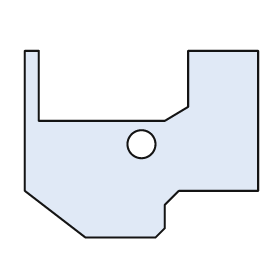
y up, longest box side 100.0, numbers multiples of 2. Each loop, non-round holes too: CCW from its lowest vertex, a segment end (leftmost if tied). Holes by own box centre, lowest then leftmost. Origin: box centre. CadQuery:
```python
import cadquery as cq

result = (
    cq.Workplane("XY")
    .moveTo(-24.0, -40.0)
    .lineTo(6.0, -40.0)
    .lineTo(10.0, -36.0)
    .lineTo(10.0, -26.0)
    .lineTo(16.0, -20.0)
    .lineTo(50.0, -20.0)
    .lineTo(50.0, 40.0)
    .lineTo(20.0, 40.0)
    .lineTo(20.0, 16.0)
    .lineTo(10.0, 10.0)
    .lineTo(-44.0, 10.0)
    .lineTo(-44.0, 40.0)
    .lineTo(-50.0, 40.0)
    .lineTo(-50.0, -20.0)
    .close()
    .moveTo(0.0, 0.0)
    .circle(6.0)
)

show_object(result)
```